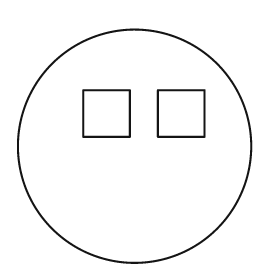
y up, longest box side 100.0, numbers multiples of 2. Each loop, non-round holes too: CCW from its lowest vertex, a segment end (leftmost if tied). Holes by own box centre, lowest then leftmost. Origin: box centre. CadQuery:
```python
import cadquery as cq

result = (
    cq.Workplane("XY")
    .moveTo(0.0, 0.0)
    .circle(50.0)
    .moveTo(-22.0, 4.0)
    .lineTo(-2.0, 4.0)
    .lineTo(-2.0, 24.0)
    .lineTo(-22.0, 24.0)
    .close()
    .moveTo(10.0, 4.0)
    .lineTo(30.0, 4.0)
    .lineTo(30.0, 24.0)
    .lineTo(10.0, 24.0)
    .close()
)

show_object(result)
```